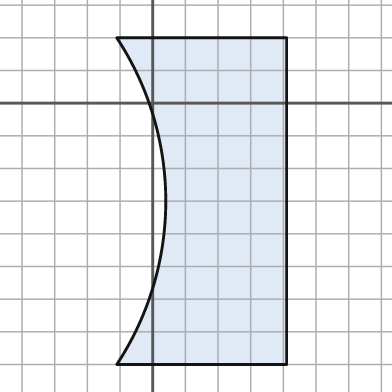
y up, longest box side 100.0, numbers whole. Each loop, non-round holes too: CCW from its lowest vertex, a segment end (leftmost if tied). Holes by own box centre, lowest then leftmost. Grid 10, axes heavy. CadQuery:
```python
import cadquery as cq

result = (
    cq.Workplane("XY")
    .moveTo(-11.0, -80.0)
    .lineTo(41.0, -80.0)
    .lineTo(41.0, 20.0)
    .lineTo(-11.0, 20.0)
    .threePointArc((4.0, -30.0), (-11.0, -80.0))
    .close()
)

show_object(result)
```